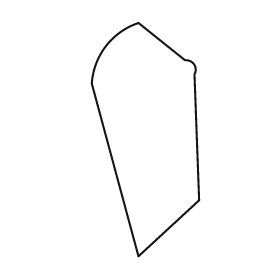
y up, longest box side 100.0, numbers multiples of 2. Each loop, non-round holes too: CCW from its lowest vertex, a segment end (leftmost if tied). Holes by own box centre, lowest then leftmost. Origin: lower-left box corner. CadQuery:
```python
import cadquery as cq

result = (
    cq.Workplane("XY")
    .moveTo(20.0, 0.0)
    .lineTo(46.0, 24.0)
    .lineTo(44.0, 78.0)
    .threePointArc((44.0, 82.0), (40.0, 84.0))
    .lineTo(20.0, 100.0)
    .threePointArc((6.0, 90.0), (0.0, 74.0))
    .close()
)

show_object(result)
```